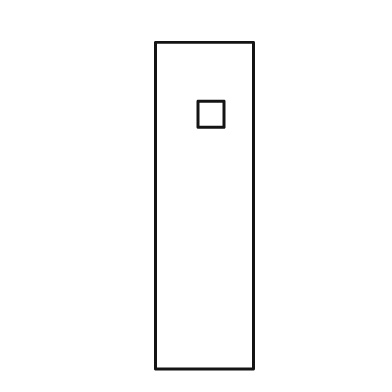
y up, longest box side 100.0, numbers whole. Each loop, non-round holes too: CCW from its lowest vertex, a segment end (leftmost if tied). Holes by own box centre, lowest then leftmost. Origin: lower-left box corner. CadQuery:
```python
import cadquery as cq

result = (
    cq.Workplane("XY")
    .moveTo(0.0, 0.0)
    .lineTo(30.0, 0.0)
    .lineTo(30.0, 100.0)
    .lineTo(0.0, 100.0)
    .close()
    .moveTo(13.0, 74.0)
    .lineTo(21.0, 74.0)
    .lineTo(21.0, 82.0)
    .lineTo(13.0, 82.0)
    .close()
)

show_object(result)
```